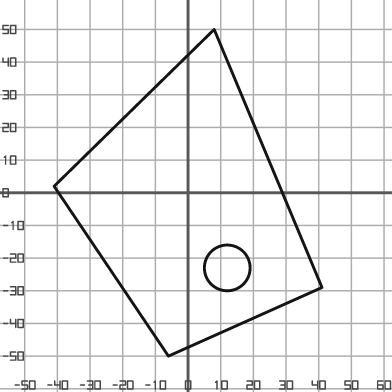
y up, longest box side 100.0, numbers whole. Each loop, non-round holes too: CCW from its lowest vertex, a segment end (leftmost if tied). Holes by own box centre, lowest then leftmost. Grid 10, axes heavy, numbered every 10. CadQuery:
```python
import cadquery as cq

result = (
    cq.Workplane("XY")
    .moveTo(-6.0, -50.0)
    .lineTo(41.0, -29.0)
    .lineTo(8.0, 50.0)
    .lineTo(-41.0, 2.0)
    .close()
    .moveTo(12.0, -23.0)
    .circle(7.0)
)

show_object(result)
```